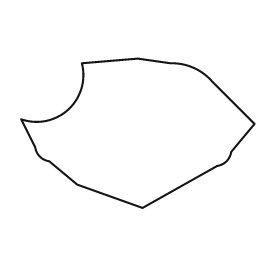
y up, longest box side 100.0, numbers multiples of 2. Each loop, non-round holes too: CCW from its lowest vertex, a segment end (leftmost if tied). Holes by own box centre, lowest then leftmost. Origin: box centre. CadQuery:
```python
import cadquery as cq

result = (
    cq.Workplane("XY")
    .moveTo(2.0, -32.0)
    .lineTo(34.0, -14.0)
    .threePointArc((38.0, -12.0), (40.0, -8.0))
    .lineTo(50.0, 4.0)
    .lineTo(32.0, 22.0)
    .threePointArc((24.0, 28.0), (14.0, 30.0))
    .lineTo(0.0, 32.0)
    .lineTo(-24.0, 30.0)
    .threePointArc((-30.0, 10.0), (-50.0, 6.0))
    .lineTo(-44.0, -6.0)
    .threePointArc((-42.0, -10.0), (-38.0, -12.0))
    .lineTo(-26.0, -22.0)
    .close()
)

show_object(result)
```